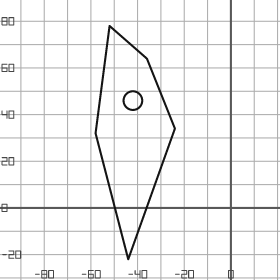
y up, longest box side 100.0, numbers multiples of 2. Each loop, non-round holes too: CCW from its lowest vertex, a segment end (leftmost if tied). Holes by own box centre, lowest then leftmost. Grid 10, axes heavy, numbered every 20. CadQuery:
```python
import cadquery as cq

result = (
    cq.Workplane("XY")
    .moveTo(-44.0, -22.0)
    .lineTo(-24.0, 34.0)
    .lineTo(-36.0, 64.0)
    .lineTo(-52.0, 78.0)
    .lineTo(-58.0, 32.0)
    .close()
    .moveTo(-42.0, 46.0)
    .circle(4.0)
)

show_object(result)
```